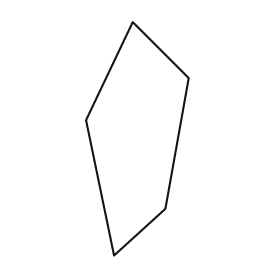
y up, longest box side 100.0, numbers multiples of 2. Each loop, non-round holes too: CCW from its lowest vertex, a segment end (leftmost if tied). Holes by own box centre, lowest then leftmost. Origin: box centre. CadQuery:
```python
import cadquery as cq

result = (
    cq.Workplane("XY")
    .moveTo(-10.0, -50.0)
    .lineTo(12.0, -30.0)
    .lineTo(22.0, 26.0)
    .lineTo(-2.0, 50.0)
    .lineTo(-22.0, 8.0)
    .close()
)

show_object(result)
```